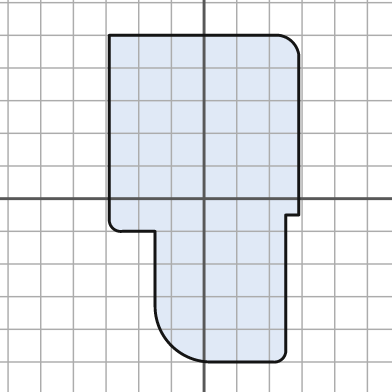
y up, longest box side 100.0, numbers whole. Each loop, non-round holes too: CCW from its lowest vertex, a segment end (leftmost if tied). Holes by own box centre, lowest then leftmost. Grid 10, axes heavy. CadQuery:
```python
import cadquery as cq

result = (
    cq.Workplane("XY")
    .moveTo(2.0, -50.0)
    .lineTo(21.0, -50.0)
    .threePointArc((24.0, -49.0), (25.0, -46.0))
    .lineTo(25.0, -5.0)
    .lineTo(29.0, -5.0)
    .lineTo(29.0, 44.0)
    .threePointArc((27.0, 48.0), (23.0, 50.0))
    .lineTo(-29.0, 50.0)
    .lineTo(-29.0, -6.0)
    .threePointArc((-28.0, -9.0), (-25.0, -10.0))
    .lineTo(-15.0, -10.0)
    .lineTo(-15.0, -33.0)
    .threePointArc((-10.0, -45.0), (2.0, -50.0))
    .close()
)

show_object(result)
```